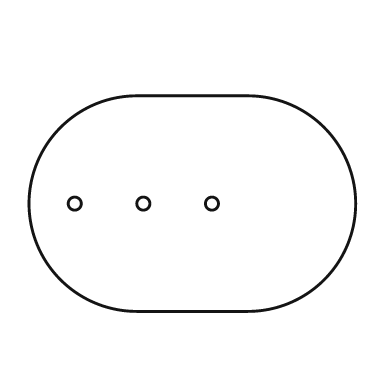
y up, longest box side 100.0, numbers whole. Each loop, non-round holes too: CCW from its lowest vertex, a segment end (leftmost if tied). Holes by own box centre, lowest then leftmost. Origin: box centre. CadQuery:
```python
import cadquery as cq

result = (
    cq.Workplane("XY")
    .moveTo(-17.0, -33.0)
    .lineTo(17.0, -33.0)
    .threePointArc((50.0, 0.0), (17.0, 33.0))
    .lineTo(-17.0, 33.0)
    .threePointArc((-50.0, 0.0), (-17.0, -33.0))
    .close()
    .moveTo(-36.0, 0.0)
    .circle(2.0)
    .moveTo(-15.0, 0.0)
    .circle(2.0)
    .moveTo(6.0, 0.0)
    .circle(2.0)
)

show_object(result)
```